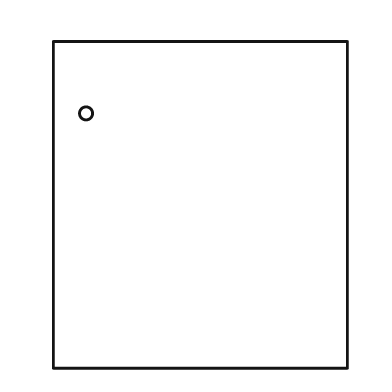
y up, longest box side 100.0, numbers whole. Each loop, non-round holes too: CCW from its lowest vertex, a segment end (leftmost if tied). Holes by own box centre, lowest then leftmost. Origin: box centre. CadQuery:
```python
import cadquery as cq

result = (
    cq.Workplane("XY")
    .moveTo(-45.0, -50.0)
    .lineTo(45.0, -50.0)
    .lineTo(45.0, 50.0)
    .lineTo(-45.0, 50.0)
    .close()
    .moveTo(-35.0, 28.0)
    .circle(2.0)
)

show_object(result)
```